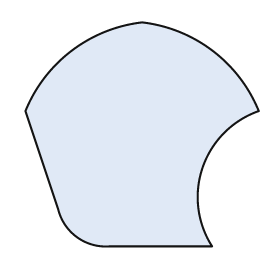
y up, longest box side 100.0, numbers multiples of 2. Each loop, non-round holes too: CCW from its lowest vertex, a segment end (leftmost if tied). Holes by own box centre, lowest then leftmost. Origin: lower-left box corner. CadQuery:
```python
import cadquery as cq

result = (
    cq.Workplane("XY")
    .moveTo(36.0, 0.0)
    .lineTo(80.0, 0.0)
    .threePointArc((76.0, 34.0), (100.0, 58.0))
    .threePointArc((80.0, 84.0), (50.0, 96.0))
    .threePointArc((20.0, 84.0), (0.0, 58.0))
    .lineTo(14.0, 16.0)
    .threePointArc((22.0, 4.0), (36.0, 0.0))
    .close()
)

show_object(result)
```